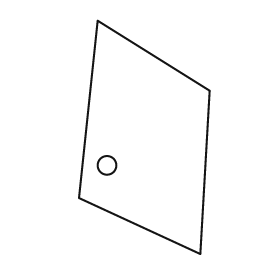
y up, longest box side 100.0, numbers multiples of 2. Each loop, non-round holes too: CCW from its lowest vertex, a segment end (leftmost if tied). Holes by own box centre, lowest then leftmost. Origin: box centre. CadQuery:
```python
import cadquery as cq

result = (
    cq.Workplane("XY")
    .moveTo(24.0, -50.0)
    .lineTo(28.0, 20.0)
    .lineTo(-20.0, 50.0)
    .lineTo(-28.0, -26.0)
    .close()
    .moveTo(-16.0, -12.0)
    .circle(4.0)
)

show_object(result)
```